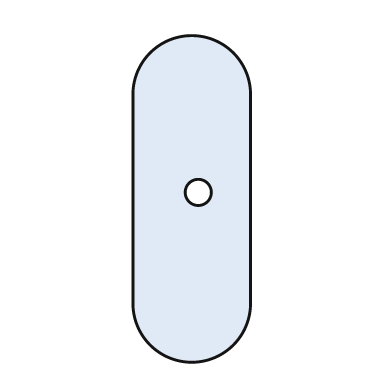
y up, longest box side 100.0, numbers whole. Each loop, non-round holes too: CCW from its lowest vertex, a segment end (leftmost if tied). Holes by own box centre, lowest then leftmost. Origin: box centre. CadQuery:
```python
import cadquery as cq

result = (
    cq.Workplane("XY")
    .moveTo(-18.0, -32.0)
    .threePointArc((0.0, -50.0), (18.0, -32.0))
    .lineTo(18.0, 32.0)
    .threePointArc((0.0, 50.0), (-18.0, 32.0))
    .close()
    .moveTo(2.0, 2.0)
    .circle(4.0)
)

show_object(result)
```